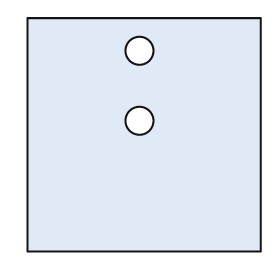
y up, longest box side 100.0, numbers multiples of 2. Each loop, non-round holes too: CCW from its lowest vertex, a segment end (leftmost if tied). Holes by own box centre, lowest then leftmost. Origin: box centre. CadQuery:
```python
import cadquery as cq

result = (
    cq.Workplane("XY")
    .moveTo(-50.0, -50.0)
    .lineTo(50.0, -50.0)
    .lineTo(50.0, 50.0)
    .lineTo(-50.0, 50.0)
    .close()
    .moveTo(-2.0, 6.0)
    .circle(6.0)
    .moveTo(-2.0, 36.0)
    .circle(6.0)
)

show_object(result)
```